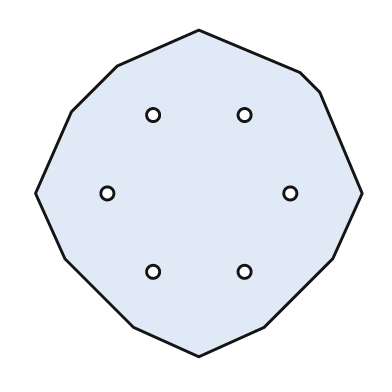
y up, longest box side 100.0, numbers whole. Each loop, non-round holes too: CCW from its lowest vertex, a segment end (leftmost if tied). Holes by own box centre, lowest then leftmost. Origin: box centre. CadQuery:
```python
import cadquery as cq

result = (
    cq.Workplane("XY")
    .moveTo(0.0, -50.0)
    .lineTo(20.0, -41.0)
    .lineTo(41.0, -20.0)
    .lineTo(50.0, 0.0)
    .lineTo(37.0, 31.0)
    .lineTo(31.0, 37.0)
    .lineTo(0.0, 50.0)
    .lineTo(-25.0, 39.0)
    .lineTo(-39.0, 25.0)
    .lineTo(-50.0, 0.0)
    .lineTo(-41.0, -20.0)
    .lineTo(-20.0, -41.0)
    .close()
    .moveTo(-14.0, -24.0)
    .circle(2.0)
    .moveTo(14.0, -24.0)
    .circle(2.0)
    .moveTo(-28.0, 0.0)
    .circle(2.0)
    .moveTo(28.0, 0.0)
    .circle(2.0)
    .moveTo(-14.0, 24.0)
    .circle(2.0)
    .moveTo(14.0, 24.0)
    .circle(2.0)
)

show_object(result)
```